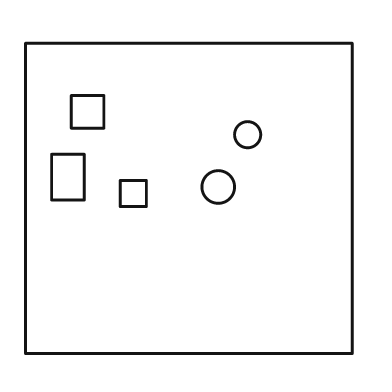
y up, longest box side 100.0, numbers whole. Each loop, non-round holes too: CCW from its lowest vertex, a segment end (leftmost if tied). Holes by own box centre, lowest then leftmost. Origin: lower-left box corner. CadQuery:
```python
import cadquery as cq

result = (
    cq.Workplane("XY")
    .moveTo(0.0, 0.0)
    .lineTo(100.0, 0.0)
    .lineTo(100.0, 95.0)
    .lineTo(0.0, 95.0)
    .close()
    .moveTo(29.0, 45.0)
    .lineTo(37.0, 45.0)
    .lineTo(37.0, 53.0)
    .lineTo(29.0, 53.0)
    .close()
    .moveTo(59.0, 51.0)
    .circle(5.0)
    .moveTo(8.0, 47.0)
    .lineTo(18.0, 47.0)
    .lineTo(18.0, 61.0)
    .lineTo(8.0, 61.0)
    .close()
    .moveTo(68.0, 67.0)
    .circle(4.0)
    .moveTo(14.0, 69.0)
    .lineTo(24.0, 69.0)
    .lineTo(24.0, 79.0)
    .lineTo(14.0, 79.0)
    .close()
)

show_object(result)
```